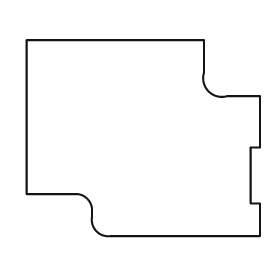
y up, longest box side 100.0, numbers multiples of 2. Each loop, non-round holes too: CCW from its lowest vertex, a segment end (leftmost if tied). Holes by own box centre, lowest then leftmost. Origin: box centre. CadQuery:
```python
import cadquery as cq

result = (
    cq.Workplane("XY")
    .moveTo(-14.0, -42.0)
    .lineTo(50.0, -42.0)
    .lineTo(50.0, -28.0)
    .lineTo(46.0, -28.0)
    .lineTo(46.0, -4.0)
    .lineTo(50.0, -4.0)
    .lineTo(50.0, 18.0)
    .lineTo(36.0, 18.0)
    .threePointArc((28.0, 20.0), (26.0, 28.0))
    .lineTo(26.0, 42.0)
    .lineTo(-50.0, 42.0)
    .lineTo(-50.0, -24.0)
    .lineTo(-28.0, -24.0)
    .threePointArc((-24.0, -26.0), (-22.0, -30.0))
    .lineTo(-22.0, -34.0)
    .threePointArc((-20.0, -40.0), (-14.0, -42.0))
    .close()
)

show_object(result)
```